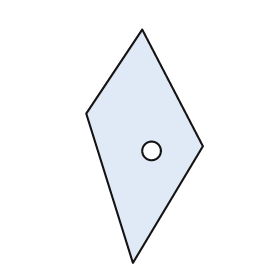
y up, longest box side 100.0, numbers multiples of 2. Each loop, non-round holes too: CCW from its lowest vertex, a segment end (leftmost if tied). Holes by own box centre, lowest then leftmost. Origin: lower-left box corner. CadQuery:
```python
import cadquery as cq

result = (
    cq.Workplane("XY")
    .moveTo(20.0, 0.0)
    .lineTo(50.0, 50.0)
    .lineTo(24.0, 100.0)
    .lineTo(0.0, 64.0)
    .close()
    .moveTo(28.0, 48.0)
    .circle(4.0)
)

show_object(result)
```